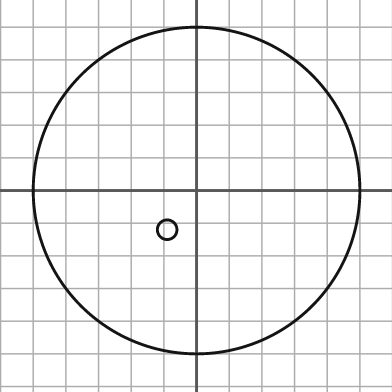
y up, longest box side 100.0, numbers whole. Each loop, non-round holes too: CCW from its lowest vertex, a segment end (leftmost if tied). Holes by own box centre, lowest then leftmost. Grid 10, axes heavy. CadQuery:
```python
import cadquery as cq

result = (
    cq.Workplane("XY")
    .moveTo(0.0, 0.0)
    .circle(50.0)
    .moveTo(-9.0, -12.0)
    .circle(3.0)
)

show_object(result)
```